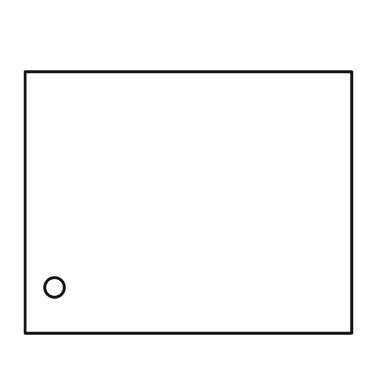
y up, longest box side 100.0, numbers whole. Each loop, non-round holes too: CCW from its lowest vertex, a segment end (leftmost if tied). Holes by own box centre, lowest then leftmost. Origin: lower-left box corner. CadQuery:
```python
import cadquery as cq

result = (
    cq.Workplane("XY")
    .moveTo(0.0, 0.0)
    .lineTo(100.0, 0.0)
    .lineTo(100.0, 80.0)
    .lineTo(0.0, 80.0)
    .close()
    .moveTo(9.0, 14.0)
    .circle(3.0)
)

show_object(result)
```